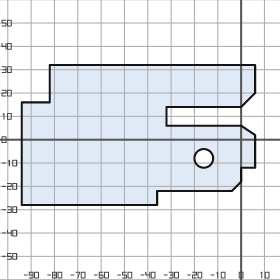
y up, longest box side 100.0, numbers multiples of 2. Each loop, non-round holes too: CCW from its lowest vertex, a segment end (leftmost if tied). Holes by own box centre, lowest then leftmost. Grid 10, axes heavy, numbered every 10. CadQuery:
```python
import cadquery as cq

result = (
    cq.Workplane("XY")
    .moveTo(-94.0, -28.0)
    .lineTo(-36.0, -28.0)
    .lineTo(-36.0, -22.0)
    .lineTo(-4.0, -22.0)
    .lineTo(0.0, -18.0)
    .lineTo(0.0, -12.0)
    .lineTo(6.0, -12.0)
    .lineTo(6.0, 2.0)
    .lineTo(0.0, 6.0)
    .lineTo(-32.0, 6.0)
    .lineTo(-32.0, 14.0)
    .lineTo(0.0, 14.0)
    .lineTo(6.0, 20.0)
    .lineTo(6.0, 32.0)
    .lineTo(-82.0, 32.0)
    .lineTo(-82.0, 16.0)
    .lineTo(-94.0, 16.0)
    .close()
    .moveTo(-16.0, -8.0)
    .circle(4.0)
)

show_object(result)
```